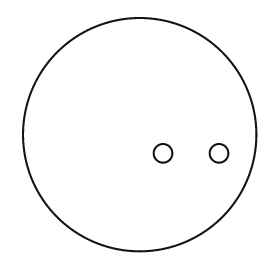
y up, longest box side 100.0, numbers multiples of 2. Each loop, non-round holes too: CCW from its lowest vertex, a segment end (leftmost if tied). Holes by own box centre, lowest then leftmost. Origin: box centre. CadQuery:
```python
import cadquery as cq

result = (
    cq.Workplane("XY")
    .moveTo(0.0, 0.0)
    .circle(50.0)
    .moveTo(10.0, -8.0)
    .circle(4.0)
    .moveTo(34.0, -8.0)
    .circle(4.0)
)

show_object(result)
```